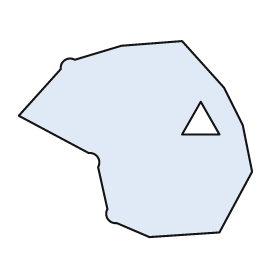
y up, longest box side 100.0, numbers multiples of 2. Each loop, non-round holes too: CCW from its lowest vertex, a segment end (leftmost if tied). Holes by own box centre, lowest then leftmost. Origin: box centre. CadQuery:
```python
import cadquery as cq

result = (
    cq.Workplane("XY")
    .moveTo(6.0, -42.0)
    .lineTo(36.0, -40.0)
    .lineTo(50.0, -14.0)
    .lineTo(46.0, 6.0)
    .lineTo(38.0, 22.0)
    .lineTo(20.0, 42.0)
    .lineTo(-6.0, 40.0)
    .lineTo(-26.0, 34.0)
    .threePointArc((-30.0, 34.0), (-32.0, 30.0))
    .lineTo(-50.0, 10.0)
    .lineTo(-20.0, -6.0)
    .threePointArc((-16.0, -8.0), (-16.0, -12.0))
    .lineTo(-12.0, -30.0)
    .threePointArc((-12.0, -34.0), (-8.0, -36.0))
    .close()
    .moveTo(20.0, 2.0)
    .lineTo(36.0, 2.0)
    .lineTo(28.0, 16.0)
    .close()
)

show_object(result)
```